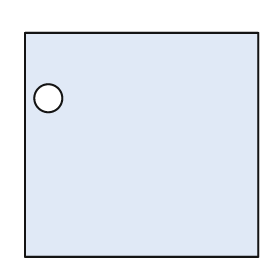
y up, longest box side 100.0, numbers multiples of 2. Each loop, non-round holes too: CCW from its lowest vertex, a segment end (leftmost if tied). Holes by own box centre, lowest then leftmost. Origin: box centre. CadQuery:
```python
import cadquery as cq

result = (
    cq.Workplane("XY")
    .moveTo(-50.0, -48.0)
    .lineTo(50.0, -48.0)
    .lineTo(50.0, 48.0)
    .lineTo(-50.0, 48.0)
    .close()
    .moveTo(-40.0, 20.0)
    .circle(6.0)
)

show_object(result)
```